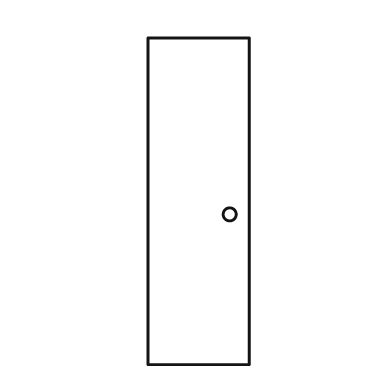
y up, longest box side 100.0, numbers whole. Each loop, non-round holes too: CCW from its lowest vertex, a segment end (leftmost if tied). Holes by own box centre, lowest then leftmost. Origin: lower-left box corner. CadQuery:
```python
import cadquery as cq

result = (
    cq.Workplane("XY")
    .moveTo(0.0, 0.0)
    .lineTo(31.0, 0.0)
    .lineTo(31.0, 100.0)
    .lineTo(0.0, 100.0)
    .close()
    .moveTo(25.0, 46.0)
    .circle(2.0)
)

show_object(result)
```